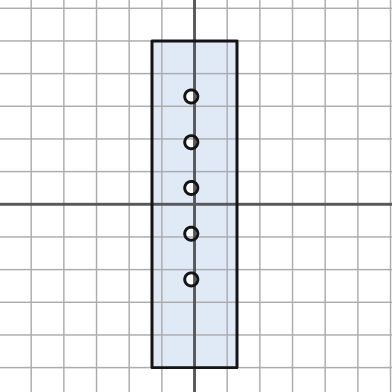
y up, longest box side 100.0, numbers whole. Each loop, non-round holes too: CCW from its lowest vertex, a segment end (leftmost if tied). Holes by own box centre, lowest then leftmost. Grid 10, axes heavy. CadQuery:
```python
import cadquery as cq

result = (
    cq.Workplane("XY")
    .moveTo(-13.0, -50.0)
    .lineTo(13.0, -50.0)
    .lineTo(13.0, 50.0)
    .lineTo(-13.0, 50.0)
    .close()
    .moveTo(-1.0, -23.0)
    .circle(2.0)
    .moveTo(-1.0, -9.0)
    .circle(2.0)
    .moveTo(-1.0, 5.0)
    .circle(2.0)
    .moveTo(-1.0, 19.0)
    .circle(2.0)
    .moveTo(-1.0, 33.0)
    .circle(2.0)
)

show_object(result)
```